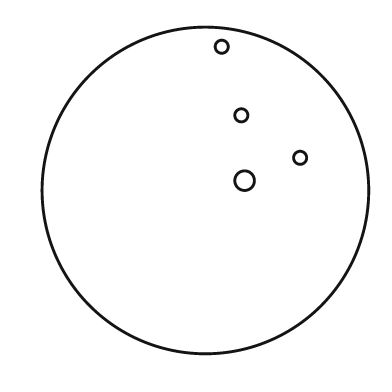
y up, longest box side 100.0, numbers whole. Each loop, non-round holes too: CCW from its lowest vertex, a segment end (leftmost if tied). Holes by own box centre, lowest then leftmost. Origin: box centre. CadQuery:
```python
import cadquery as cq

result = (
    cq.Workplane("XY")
    .moveTo(0.0, 0.0)
    .circle(50.0)
    .moveTo(12.0, 3.0)
    .circle(3.0)
    .moveTo(29.0, 10.0)
    .circle(2.0)
    .moveTo(11.0, 23.0)
    .circle(2.0)
    .moveTo(5.0, 44.0)
    .circle(2.0)
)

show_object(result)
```